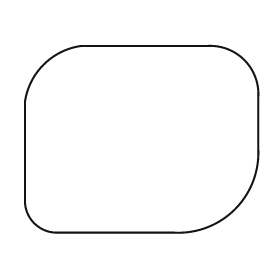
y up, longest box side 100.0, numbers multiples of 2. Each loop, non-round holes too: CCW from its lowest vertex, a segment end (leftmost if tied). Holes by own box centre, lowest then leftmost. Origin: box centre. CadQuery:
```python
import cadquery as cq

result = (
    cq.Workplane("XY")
    .moveTo(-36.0, -40.0)
    .lineTo(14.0, -40.0)
    .threePointArc((40.0, -30.0), (50.0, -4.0))
    .lineTo(50.0, 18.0)
    .threePointArc((44.0, 34.0), (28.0, 40.0))
    .lineTo(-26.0, 40.0)
    .threePointArc((-42.0, 32.0), (-50.0, 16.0))
    .lineTo(-50.0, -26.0)
    .threePointArc((-46.0, -36.0), (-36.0, -40.0))
    .close()
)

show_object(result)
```